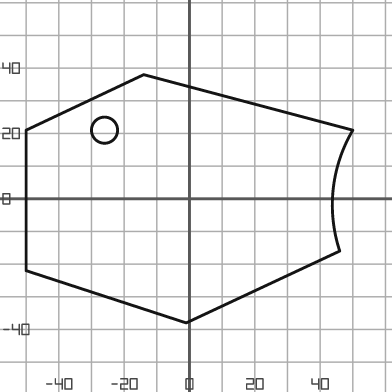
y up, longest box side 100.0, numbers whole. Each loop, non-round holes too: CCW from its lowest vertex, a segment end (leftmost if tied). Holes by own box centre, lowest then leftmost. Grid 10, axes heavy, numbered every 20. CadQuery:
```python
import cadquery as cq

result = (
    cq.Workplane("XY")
    .moveTo(-1.0, -38.0)
    .lineTo(46.0, -16.0)
    .threePointArc((44.0, 3.0), (50.0, 21.0))
    .lineTo(-14.0, 38.0)
    .lineTo(-50.0, 21.0)
    .lineTo(-50.0, -22.0)
    .close()
    .moveTo(-26.0, 21.0)
    .circle(4.0)
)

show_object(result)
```